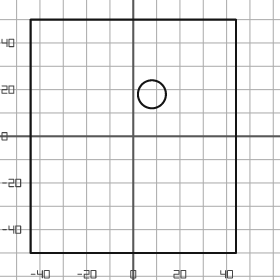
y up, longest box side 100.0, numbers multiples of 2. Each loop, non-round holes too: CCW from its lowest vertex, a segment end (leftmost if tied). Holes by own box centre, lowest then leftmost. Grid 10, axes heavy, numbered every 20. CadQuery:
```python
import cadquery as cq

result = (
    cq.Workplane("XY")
    .moveTo(-44.0, -50.0)
    .lineTo(44.0, -50.0)
    .lineTo(44.0, 50.0)
    .lineTo(-44.0, 50.0)
    .close()
    .moveTo(8.0, 18.0)
    .circle(6.0)
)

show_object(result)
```